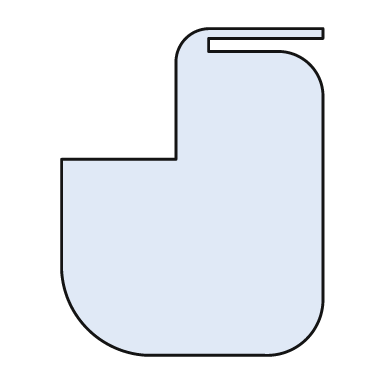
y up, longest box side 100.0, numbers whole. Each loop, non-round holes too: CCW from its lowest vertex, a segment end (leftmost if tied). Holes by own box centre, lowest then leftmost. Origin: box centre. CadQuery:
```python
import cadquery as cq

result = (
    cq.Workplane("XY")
    .moveTo(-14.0, -50.0)
    .lineTo(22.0, -50.0)
    .threePointArc((35.0, -45.0), (40.0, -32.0))
    .lineTo(40.0, 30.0)
    .threePointArc((36.0, 39.0), (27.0, 43.0))
    .lineTo(5.0, 43.0)
    .lineTo(5.0, 47.0)
    .lineTo(40.0, 47.0)
    .lineTo(40.0, 50.0)
    .lineTo(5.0, 50.0)
    .threePointArc((-2.0, 47.0), (-5.0, 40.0))
    .lineTo(-5.0, 10.0)
    .lineTo(-40.0, 10.0)
    .lineTo(-40.0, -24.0)
    .threePointArc((-32.0, -42.0), (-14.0, -50.0))
    .close()
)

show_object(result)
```